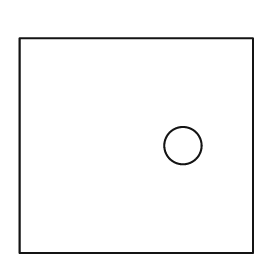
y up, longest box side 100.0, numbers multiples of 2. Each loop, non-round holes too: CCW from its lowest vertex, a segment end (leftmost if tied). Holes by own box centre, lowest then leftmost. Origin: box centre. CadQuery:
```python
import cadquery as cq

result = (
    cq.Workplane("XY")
    .moveTo(-50.0, -46.0)
    .lineTo(50.0, -46.0)
    .lineTo(50.0, 46.0)
    .lineTo(-50.0, 46.0)
    .close()
    .moveTo(20.0, 0.0)
    .circle(8.0)
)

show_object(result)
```